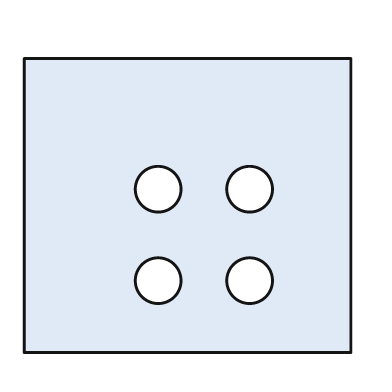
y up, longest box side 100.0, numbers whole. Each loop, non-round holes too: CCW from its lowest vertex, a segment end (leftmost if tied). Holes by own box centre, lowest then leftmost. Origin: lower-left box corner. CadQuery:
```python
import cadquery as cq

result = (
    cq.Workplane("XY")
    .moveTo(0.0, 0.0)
    .lineTo(100.0, 0.0)
    .lineTo(100.0, 90.0)
    .lineTo(0.0, 90.0)
    .close()
    .moveTo(41.0, 22.0)
    .circle(7.0)
    .moveTo(69.0, 22.0)
    .circle(7.0)
    .moveTo(41.0, 50.0)
    .circle(7.0)
    .moveTo(69.0, 50.0)
    .circle(7.0)
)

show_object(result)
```